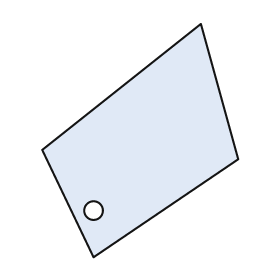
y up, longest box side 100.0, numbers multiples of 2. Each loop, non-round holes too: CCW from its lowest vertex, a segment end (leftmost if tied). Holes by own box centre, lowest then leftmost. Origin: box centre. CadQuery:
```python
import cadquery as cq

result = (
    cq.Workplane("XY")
    .moveTo(-20.0, -50.0)
    .lineTo(42.0, -8.0)
    .lineTo(26.0, 50.0)
    .lineTo(-42.0, -4.0)
    .close()
    .moveTo(-20.0, -30.0)
    .circle(4.0)
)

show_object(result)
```